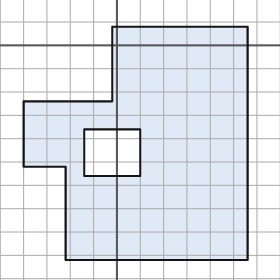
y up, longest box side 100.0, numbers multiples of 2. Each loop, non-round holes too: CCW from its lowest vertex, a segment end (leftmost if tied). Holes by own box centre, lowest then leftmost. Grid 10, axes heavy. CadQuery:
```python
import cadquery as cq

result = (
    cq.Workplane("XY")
    .moveTo(-22.0, -92.0)
    .lineTo(56.0, -92.0)
    .lineTo(56.0, 8.0)
    .lineTo(-2.0, 8.0)
    .lineTo(-2.0, -24.0)
    .lineTo(-40.0, -24.0)
    .lineTo(-40.0, -52.0)
    .lineTo(-22.0, -52.0)
    .close()
    .moveTo(-14.0, -56.0)
    .lineTo(10.0, -56.0)
    .lineTo(10.0, -36.0)
    .lineTo(-14.0, -36.0)
    .close()
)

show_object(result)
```